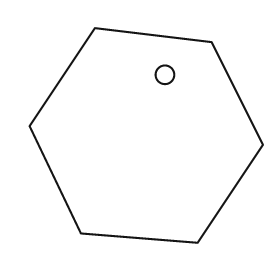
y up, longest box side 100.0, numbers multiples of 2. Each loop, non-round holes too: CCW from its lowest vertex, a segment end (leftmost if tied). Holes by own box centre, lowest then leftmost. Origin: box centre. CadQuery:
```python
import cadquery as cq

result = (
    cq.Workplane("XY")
    .moveTo(22.0, -46.0)
    .lineTo(50.0, -4.0)
    .lineTo(28.0, 40.0)
    .lineTo(-22.0, 46.0)
    .lineTo(-50.0, 4.0)
    .lineTo(-28.0, -42.0)
    .close()
    .moveTo(8.0, 26.0)
    .circle(4.0)
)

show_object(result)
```